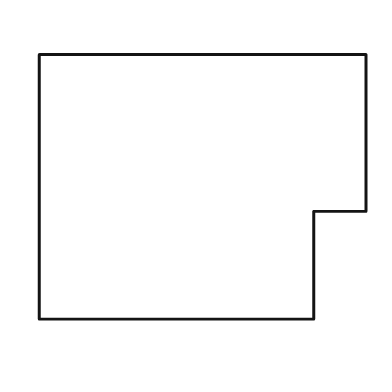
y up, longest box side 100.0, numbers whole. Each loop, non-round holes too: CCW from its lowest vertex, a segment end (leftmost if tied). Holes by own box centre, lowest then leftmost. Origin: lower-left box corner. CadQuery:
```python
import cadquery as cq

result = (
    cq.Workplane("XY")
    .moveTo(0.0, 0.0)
    .lineTo(84.0, 0.0)
    .lineTo(84.0, 33.0)
    .lineTo(100.0, 33.0)
    .lineTo(100.0, 81.0)
    .lineTo(0.0, 81.0)
    .close()
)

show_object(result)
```